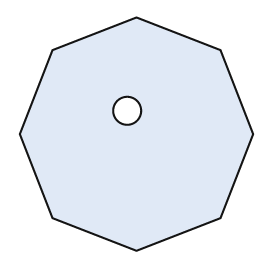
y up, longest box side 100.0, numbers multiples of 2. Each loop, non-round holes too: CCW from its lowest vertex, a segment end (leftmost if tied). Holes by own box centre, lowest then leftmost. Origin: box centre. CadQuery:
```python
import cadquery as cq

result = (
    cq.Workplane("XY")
    .moveTo(0.0, -50.0)
    .lineTo(36.0, -36.0)
    .lineTo(50.0, 0.0)
    .lineTo(36.0, 36.0)
    .lineTo(0.0, 50.0)
    .lineTo(-36.0, 36.0)
    .lineTo(-50.0, 0.0)
    .lineTo(-36.0, -36.0)
    .close()
    .moveTo(-4.0, 10.0)
    .circle(6.0)
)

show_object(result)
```